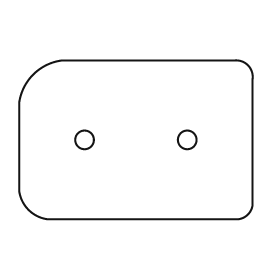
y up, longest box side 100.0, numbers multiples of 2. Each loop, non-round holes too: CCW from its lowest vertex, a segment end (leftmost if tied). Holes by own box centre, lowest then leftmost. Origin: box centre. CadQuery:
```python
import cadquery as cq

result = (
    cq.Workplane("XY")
    .moveTo(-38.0, -34.0)
    .lineTo(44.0, -34.0)
    .threePointArc((48.0, -32.0), (50.0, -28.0))
    .lineTo(50.0, 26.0)
    .threePointArc((48.0, 32.0), (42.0, 34.0))
    .lineTo(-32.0, 34.0)
    .threePointArc((-44.0, 28.0), (-50.0, 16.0))
    .lineTo(-50.0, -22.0)
    .threePointArc((-46.0, -30.0), (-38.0, -34.0))
    .close()
    .moveTo(-22.0, 0.0)
    .circle(4.0)
    .moveTo(22.0, 0.0)
    .circle(4.0)
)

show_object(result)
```